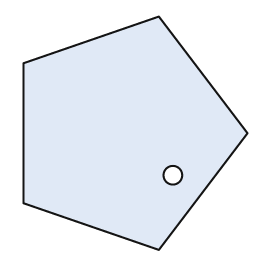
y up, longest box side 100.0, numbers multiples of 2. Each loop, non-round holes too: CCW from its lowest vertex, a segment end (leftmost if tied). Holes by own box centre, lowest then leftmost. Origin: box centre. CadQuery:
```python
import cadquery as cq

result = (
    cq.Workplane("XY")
    .moveTo(10.0, -50.0)
    .lineTo(48.0, 0.0)
    .lineTo(10.0, 50.0)
    .lineTo(-48.0, 30.0)
    .lineTo(-48.0, -30.0)
    .close()
    .moveTo(16.0, -18.0)
    .circle(4.0)
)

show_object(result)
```